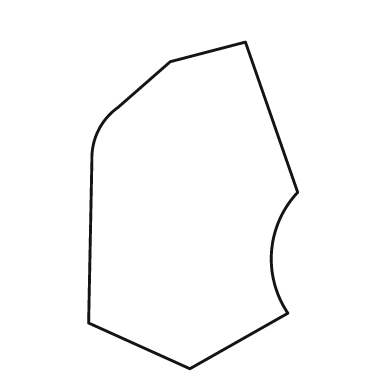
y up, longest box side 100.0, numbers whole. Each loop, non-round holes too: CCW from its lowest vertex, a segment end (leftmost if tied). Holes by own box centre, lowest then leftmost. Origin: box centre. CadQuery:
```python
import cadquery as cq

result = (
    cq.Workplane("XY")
    .moveTo(-1.0, -50.0)
    .lineTo(29.0, -33.0)
    .threePointArc((24.0, -14.0), (32.0, 4.0))
    .lineTo(16.0, 50.0)
    .lineTo(-7.0, 44.0)
    .lineTo(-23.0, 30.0)
    .threePointArc((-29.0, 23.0), (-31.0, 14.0))
    .lineTo(-32.0, -36.0)
    .close()
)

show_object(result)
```